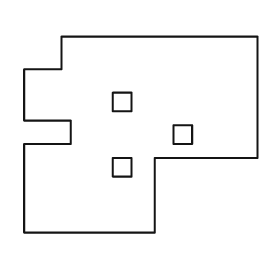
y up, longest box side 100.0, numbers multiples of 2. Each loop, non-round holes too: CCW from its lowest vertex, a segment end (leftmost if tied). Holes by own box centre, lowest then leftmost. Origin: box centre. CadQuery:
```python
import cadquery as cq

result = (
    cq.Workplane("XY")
    .moveTo(-50.0, -42.0)
    .lineTo(6.0, -42.0)
    .lineTo(6.0, -10.0)
    .lineTo(50.0, -10.0)
    .lineTo(50.0, 42.0)
    .lineTo(-34.0, 42.0)
    .lineTo(-34.0, 28.0)
    .lineTo(-50.0, 28.0)
    .lineTo(-50.0, 6.0)
    .lineTo(-30.0, 6.0)
    .lineTo(-30.0, -4.0)
    .lineTo(-50.0, -4.0)
    .close()
    .moveTo(-12.0, -18.0)
    .lineTo(-4.0, -18.0)
    .lineTo(-4.0, -10.0)
    .lineTo(-12.0, -10.0)
    .close()
    .moveTo(14.0, -4.0)
    .lineTo(22.0, -4.0)
    .lineTo(22.0, 4.0)
    .lineTo(14.0, 4.0)
    .close()
    .moveTo(-12.0, 10.0)
    .lineTo(-4.0, 10.0)
    .lineTo(-4.0, 18.0)
    .lineTo(-12.0, 18.0)
    .close()
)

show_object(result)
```